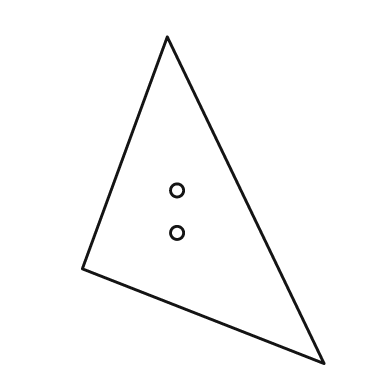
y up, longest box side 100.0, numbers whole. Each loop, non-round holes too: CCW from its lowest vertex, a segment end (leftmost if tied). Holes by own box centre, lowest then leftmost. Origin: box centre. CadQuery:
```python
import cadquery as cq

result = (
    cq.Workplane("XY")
    .moveTo(37.0, -50.0)
    .lineTo(-11.0, 50.0)
    .lineTo(-37.0, -21.0)
    .close()
    .moveTo(-8.0, -10.0)
    .circle(2.0)
    .moveTo(-8.0, 3.0)
    .circle(2.0)
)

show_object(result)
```